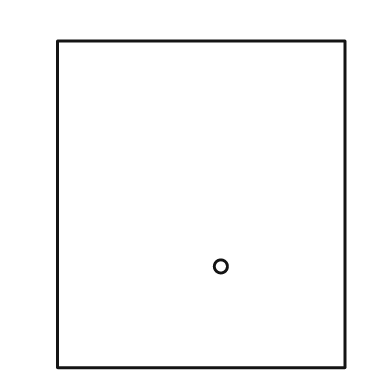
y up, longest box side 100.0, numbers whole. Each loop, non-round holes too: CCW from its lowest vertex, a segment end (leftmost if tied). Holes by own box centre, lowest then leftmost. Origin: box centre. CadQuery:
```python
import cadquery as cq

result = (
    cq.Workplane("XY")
    .moveTo(-44.0, -50.0)
    .lineTo(44.0, -50.0)
    .lineTo(44.0, 50.0)
    .lineTo(-44.0, 50.0)
    .close()
    .moveTo(6.0, -19.0)
    .circle(2.0)
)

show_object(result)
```